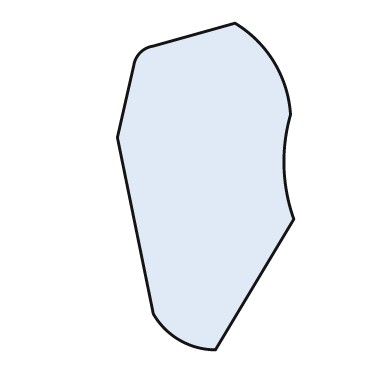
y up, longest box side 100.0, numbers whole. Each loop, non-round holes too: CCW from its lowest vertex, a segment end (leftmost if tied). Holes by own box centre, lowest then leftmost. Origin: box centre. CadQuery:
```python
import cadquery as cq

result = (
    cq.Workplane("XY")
    .moveTo(3.0, -50.0)
    .lineTo(27.0, -10.0)
    .threePointArc((24.0, 6.0), (26.0, 22.0))
    .threePointArc((21.0, 38.0), (9.0, 50.0))
    .lineTo(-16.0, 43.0)
    .threePointArc((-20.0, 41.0), (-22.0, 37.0))
    .lineTo(-27.0, 15.0)
    .lineTo(-16.0, -39.0)
    .threePointArc((-8.0, -47.0), (3.0, -50.0))
    .close()
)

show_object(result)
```